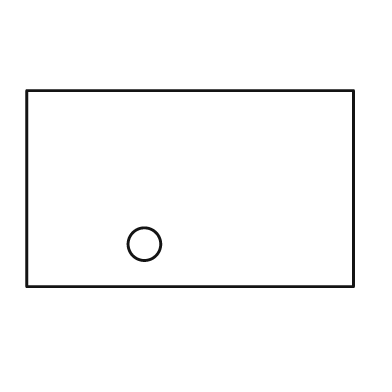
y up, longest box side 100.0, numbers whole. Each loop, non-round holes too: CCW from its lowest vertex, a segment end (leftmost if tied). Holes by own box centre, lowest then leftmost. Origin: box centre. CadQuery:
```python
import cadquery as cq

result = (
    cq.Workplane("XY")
    .moveTo(-50.0, -30.0)
    .lineTo(50.0, -30.0)
    .lineTo(50.0, 30.0)
    .lineTo(-50.0, 30.0)
    .close()
    .moveTo(-14.0, -17.0)
    .circle(5.0)
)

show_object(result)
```